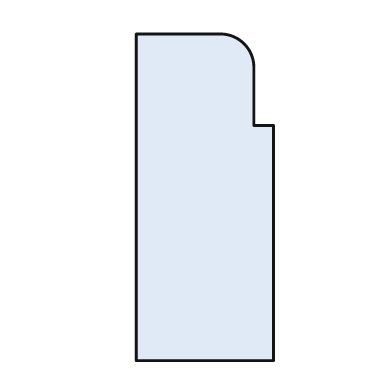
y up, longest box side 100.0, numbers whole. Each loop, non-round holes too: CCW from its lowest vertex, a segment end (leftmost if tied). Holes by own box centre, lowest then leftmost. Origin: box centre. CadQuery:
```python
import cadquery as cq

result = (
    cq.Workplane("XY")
    .moveTo(-21.0, -50.0)
    .lineTo(21.0, -50.0)
    .lineTo(21.0, 22.0)
    .lineTo(15.0, 22.0)
    .lineTo(15.0, 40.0)
    .threePointArc((12.0, 47.0), (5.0, 50.0))
    .lineTo(-21.0, 50.0)
    .close()
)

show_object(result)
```